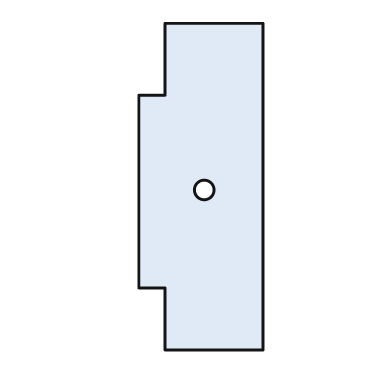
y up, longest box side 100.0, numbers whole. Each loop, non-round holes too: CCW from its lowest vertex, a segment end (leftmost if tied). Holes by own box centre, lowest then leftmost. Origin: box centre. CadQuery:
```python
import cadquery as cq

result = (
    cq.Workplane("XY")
    .moveTo(-11.0, -50.0)
    .lineTo(19.0, -50.0)
    .lineTo(19.0, 50.0)
    .lineTo(-11.0, 50.0)
    .lineTo(-11.0, 28.0)
    .lineTo(-19.0, 28.0)
    .lineTo(-19.0, -31.0)
    .lineTo(-11.0, -31.0)
    .close()
    .moveTo(1.0, -1.0)
    .circle(3.0)
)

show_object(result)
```